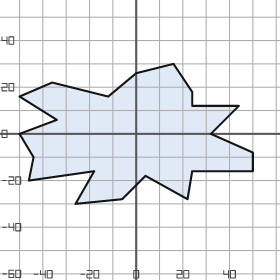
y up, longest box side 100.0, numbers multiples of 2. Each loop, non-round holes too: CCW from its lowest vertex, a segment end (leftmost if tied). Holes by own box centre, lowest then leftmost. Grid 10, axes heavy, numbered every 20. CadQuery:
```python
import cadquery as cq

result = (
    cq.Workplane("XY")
    .moveTo(-26.0, -30.0)
    .lineTo(-6.0, -28.0)
    .lineTo(4.0, -18.0)
    .lineTo(22.0, -28.0)
    .lineTo(24.0, -16.0)
    .lineTo(50.0, -16.0)
    .lineTo(50.0, -8.0)
    .lineTo(32.0, 0.0)
    .lineTo(44.0, 12.0)
    .lineTo(24.0, 12.0)
    .lineTo(24.0, 18.0)
    .lineTo(16.0, 30.0)
    .lineTo(0.0, 26.0)
    .lineTo(-12.0, 16.0)
    .lineTo(-36.0, 22.0)
    .lineTo(-50.0, 16.0)
    .lineTo(-34.0, 6.0)
    .lineTo(-50.0, 0.0)
    .lineTo(-44.0, -10.0)
    .lineTo(-46.0, -20.0)
    .lineTo(-18.0, -16.0)
    .close()
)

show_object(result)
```